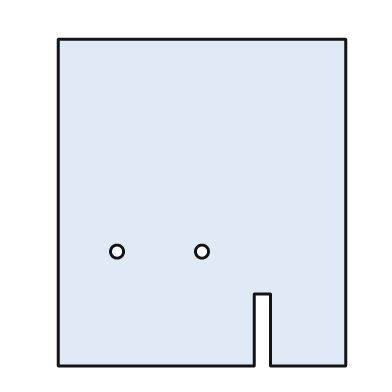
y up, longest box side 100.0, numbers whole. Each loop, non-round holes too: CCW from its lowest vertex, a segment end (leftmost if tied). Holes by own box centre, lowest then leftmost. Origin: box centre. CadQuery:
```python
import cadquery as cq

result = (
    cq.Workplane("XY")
    .moveTo(-44.0, -50.0)
    .lineTo(16.0, -50.0)
    .lineTo(16.0, -28.0)
    .lineTo(21.0, -28.0)
    .lineTo(21.0, -50.0)
    .lineTo(44.0, -50.0)
    .lineTo(44.0, 50.0)
    .lineTo(-44.0, 50.0)
    .close()
    .moveTo(-26.0, -15.0)
    .circle(2.0)
    .moveTo(0.0, -15.0)
    .circle(2.0)
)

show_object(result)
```